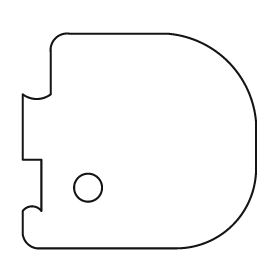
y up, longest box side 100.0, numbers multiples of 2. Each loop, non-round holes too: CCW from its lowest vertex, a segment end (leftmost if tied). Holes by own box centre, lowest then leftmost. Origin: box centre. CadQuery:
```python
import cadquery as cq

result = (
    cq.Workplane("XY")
    .moveTo(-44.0, -46.0)
    .lineTo(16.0, -46.0)
    .threePointArc((40.0, -36.0), (50.0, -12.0))
    .lineTo(50.0, 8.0)
    .threePointArc((38.0, 34.0), (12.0, 46.0))
    .lineTo(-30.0, 46.0)
    .threePointArc((-36.0, 44.0), (-38.0, 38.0))
    .lineTo(-38.0, 20.0)
    .threePointArc((-44.0, 18.0), (-50.0, 20.0))
    .lineTo(-50.0, -8.0)
    .lineTo(-42.0, -8.0)
    .lineTo(-42.0, -30.0)
    .threePointArc((-46.0, -28.0), (-50.0, -30.0))
    .lineTo(-50.0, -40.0)
    .threePointArc((-48.0, -44.0), (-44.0, -46.0))
    .close()
    .moveTo(-22.0, -20.0)
    .circle(6.0)
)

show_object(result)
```